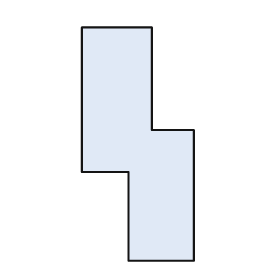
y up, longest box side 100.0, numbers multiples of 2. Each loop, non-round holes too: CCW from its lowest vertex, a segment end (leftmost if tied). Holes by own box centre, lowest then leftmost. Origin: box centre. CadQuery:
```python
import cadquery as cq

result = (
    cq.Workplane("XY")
    .moveTo(-4.0, -50.0)
    .lineTo(24.0, -50.0)
    .lineTo(24.0, 6.0)
    .lineTo(6.0, 6.0)
    .lineTo(6.0, 50.0)
    .lineTo(-24.0, 50.0)
    .lineTo(-24.0, -12.0)
    .lineTo(-4.0, -12.0)
    .close()
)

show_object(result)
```